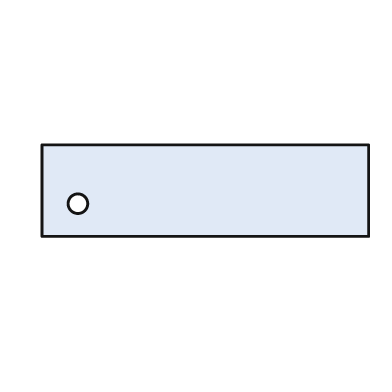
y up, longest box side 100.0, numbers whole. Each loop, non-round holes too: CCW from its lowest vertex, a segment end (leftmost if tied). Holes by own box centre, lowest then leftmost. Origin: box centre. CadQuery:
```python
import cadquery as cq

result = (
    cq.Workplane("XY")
    .moveTo(-50.0, -14.0)
    .lineTo(50.0, -14.0)
    .lineTo(50.0, 14.0)
    .lineTo(-50.0, 14.0)
    .close()
    .moveTo(-39.0, -4.0)
    .circle(3.0)
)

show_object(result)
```